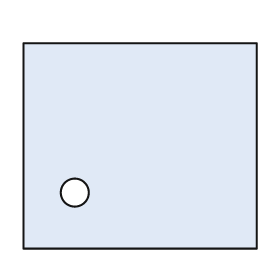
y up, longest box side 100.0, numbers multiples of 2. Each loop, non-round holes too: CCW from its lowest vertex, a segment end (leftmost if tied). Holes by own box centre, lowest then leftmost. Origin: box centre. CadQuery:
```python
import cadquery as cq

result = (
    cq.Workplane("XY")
    .moveTo(-50.0, -44.0)
    .lineTo(50.0, -44.0)
    .lineTo(50.0, 44.0)
    .lineTo(-50.0, 44.0)
    .close()
    .moveTo(-28.0, -20.0)
    .circle(6.0)
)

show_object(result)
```